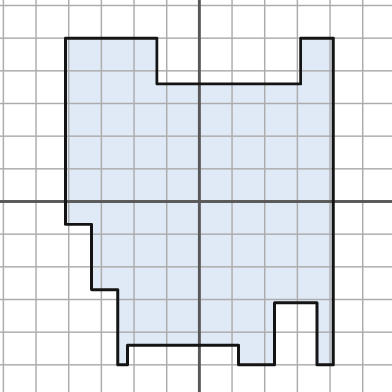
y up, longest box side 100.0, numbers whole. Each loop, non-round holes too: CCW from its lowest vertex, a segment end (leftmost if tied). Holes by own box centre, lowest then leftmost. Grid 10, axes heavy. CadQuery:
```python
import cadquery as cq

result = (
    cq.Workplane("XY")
    .moveTo(-25.0, -50.0)
    .lineTo(-22.0, -50.0)
    .lineTo(-22.0, -44.0)
    .lineTo(12.0, -44.0)
    .lineTo(12.0, -50.0)
    .lineTo(23.0, -50.0)
    .lineTo(23.0, -31.0)
    .lineTo(36.0, -31.0)
    .lineTo(36.0, -50.0)
    .lineTo(41.0, -50.0)
    .lineTo(41.0, 50.0)
    .lineTo(31.0, 50.0)
    .lineTo(31.0, 36.0)
    .lineTo(-13.0, 36.0)
    .lineTo(-13.0, 50.0)
    .lineTo(-41.0, 50.0)
    .lineTo(-41.0, -7.0)
    .lineTo(-33.0, -7.0)
    .lineTo(-33.0, -27.0)
    .lineTo(-25.0, -27.0)
    .close()
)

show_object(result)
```